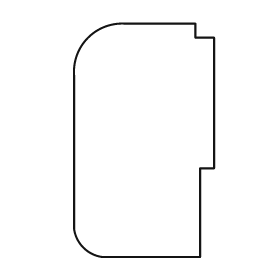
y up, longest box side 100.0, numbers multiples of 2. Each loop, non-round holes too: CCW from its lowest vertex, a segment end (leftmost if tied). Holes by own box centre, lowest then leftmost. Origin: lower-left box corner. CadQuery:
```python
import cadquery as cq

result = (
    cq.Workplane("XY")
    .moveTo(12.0, 0.0)
    .lineTo(54.0, 0.0)
    .lineTo(54.0, 38.0)
    .lineTo(60.0, 38.0)
    .lineTo(60.0, 94.0)
    .lineTo(52.0, 94.0)
    .lineTo(52.0, 100.0)
    .lineTo(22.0, 100.0)
    .threePointArc((6.0, 94.0), (0.0, 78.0))
    .lineTo(0.0, 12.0)
    .threePointArc((4.0, 4.0), (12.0, 0.0))
    .close()
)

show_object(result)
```